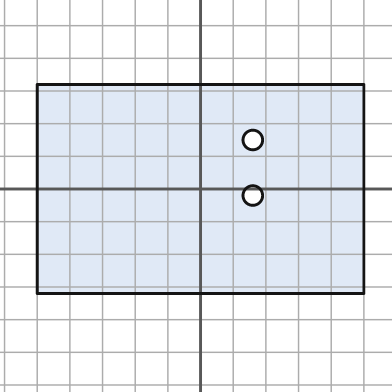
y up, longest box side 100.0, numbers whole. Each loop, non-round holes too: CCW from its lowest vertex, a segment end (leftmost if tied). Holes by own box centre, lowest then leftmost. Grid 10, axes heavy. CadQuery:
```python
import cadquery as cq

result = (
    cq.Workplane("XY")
    .moveTo(-50.0, -32.0)
    .lineTo(50.0, -32.0)
    .lineTo(50.0, 32.0)
    .lineTo(-50.0, 32.0)
    .close()
    .moveTo(16.0, -2.0)
    .circle(3.0)
    .moveTo(16.0, 15.0)
    .circle(3.0)
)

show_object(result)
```